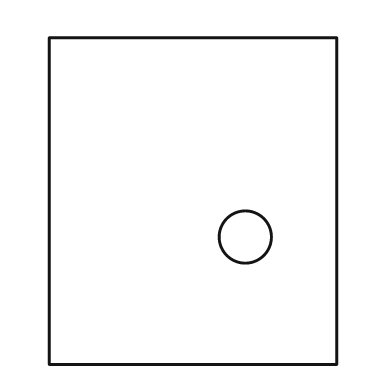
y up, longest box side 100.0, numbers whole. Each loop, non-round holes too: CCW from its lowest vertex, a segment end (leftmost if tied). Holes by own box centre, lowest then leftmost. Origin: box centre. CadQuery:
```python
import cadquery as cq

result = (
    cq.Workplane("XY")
    .moveTo(-44.0, -50.0)
    .lineTo(44.0, -50.0)
    .lineTo(44.0, 50.0)
    .lineTo(-44.0, 50.0)
    .close()
    .moveTo(16.0, -11.0)
    .circle(8.0)
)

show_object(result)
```